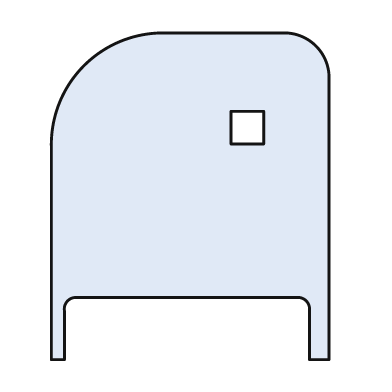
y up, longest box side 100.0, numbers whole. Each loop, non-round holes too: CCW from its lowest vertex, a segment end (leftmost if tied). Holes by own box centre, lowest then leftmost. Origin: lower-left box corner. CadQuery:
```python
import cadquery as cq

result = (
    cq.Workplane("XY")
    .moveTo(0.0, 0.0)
    .lineTo(4.0, 0.0)
    .lineTo(4.0, 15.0)
    .threePointArc((5.0, 18.0), (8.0, 19.0))
    .lineTo(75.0, 19.0)
    .threePointArc((78.0, 18.0), (79.0, 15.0))
    .lineTo(79.0, 0.0)
    .lineTo(85.0, 0.0)
    .lineTo(85.0, 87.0)
    .threePointArc((81.0, 96.0), (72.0, 100.0))
    .lineTo(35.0, 100.0)
    .threePointArc((10.0, 90.0), (0.0, 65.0))
    .close()
    .moveTo(55.0, 66.0)
    .lineTo(65.0, 66.0)
    .lineTo(65.0, 76.0)
    .lineTo(55.0, 76.0)
    .close()
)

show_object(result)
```